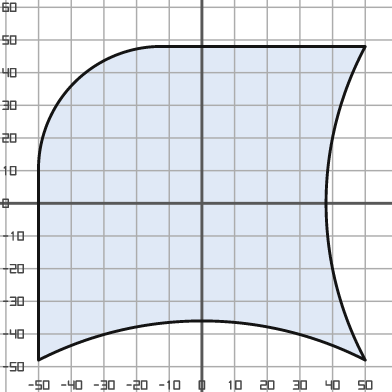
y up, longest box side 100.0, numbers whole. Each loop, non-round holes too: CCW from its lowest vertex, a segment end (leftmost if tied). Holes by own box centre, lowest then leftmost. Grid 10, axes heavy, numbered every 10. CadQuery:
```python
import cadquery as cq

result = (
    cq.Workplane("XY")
    .moveTo(-50.0, -48.0)
    .threePointArc((0.0, -36.0), (50.0, -48.0))
    .threePointArc((38.0, 0.0), (50.0, 48.0))
    .lineTo(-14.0, 48.0)
    .threePointArc((-39.0, 37.0), (-50.0, 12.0))
    .close()
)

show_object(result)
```